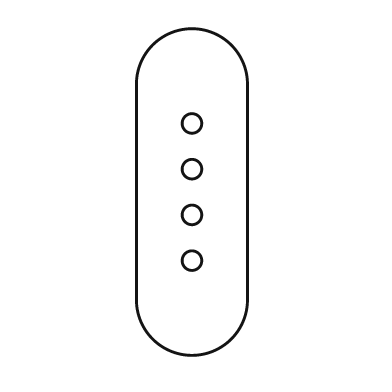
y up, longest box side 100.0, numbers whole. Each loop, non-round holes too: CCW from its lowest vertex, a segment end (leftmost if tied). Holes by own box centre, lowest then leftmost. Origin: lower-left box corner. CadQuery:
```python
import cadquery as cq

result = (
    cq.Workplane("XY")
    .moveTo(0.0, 17.0)
    .threePointArc((17.0, 0.0), (34.0, 17.0))
    .lineTo(34.0, 83.0)
    .threePointArc((17.0, 100.0), (0.0, 83.0))
    .close()
    .moveTo(17.0, 29.0)
    .circle(3.0)
    .moveTo(17.0, 43.0)
    .circle(3.0)
    .moveTo(17.0, 57.0)
    .circle(3.0)
    .moveTo(17.0, 71.0)
    .circle(3.0)
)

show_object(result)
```